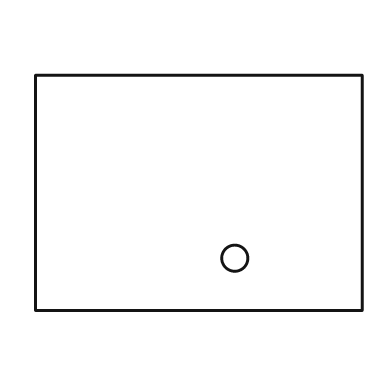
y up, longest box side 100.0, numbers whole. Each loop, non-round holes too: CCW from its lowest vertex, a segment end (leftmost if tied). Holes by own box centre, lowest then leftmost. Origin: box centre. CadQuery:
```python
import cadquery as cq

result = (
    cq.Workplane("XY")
    .moveTo(-50.0, -36.0)
    .lineTo(50.0, -36.0)
    .lineTo(50.0, 36.0)
    .lineTo(-50.0, 36.0)
    .close()
    .moveTo(11.0, -20.0)
    .circle(4.0)
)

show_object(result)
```